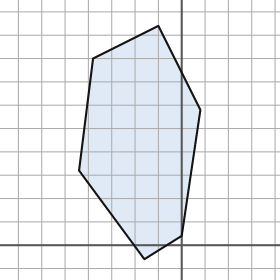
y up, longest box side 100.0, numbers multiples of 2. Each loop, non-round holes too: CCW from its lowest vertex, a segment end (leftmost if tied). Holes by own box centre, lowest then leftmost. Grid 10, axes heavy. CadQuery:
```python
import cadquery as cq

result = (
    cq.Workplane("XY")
    .moveTo(-16.0, -6.0)
    .lineTo(0.0, 4.0)
    .lineTo(8.0, 58.0)
    .lineTo(-10.0, 94.0)
    .lineTo(-38.0, 80.0)
    .lineTo(-44.0, 32.0)
    .close()
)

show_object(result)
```